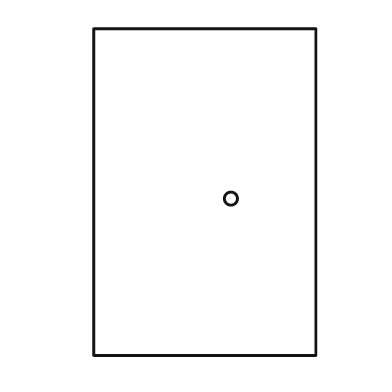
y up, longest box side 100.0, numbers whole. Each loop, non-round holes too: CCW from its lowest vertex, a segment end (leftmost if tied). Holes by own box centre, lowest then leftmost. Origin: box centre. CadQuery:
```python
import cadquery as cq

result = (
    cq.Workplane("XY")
    .moveTo(-34.0, -50.0)
    .lineTo(34.0, -50.0)
    .lineTo(34.0, 50.0)
    .lineTo(-34.0, 50.0)
    .close()
    .moveTo(8.0, -2.0)
    .circle(2.0)
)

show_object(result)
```